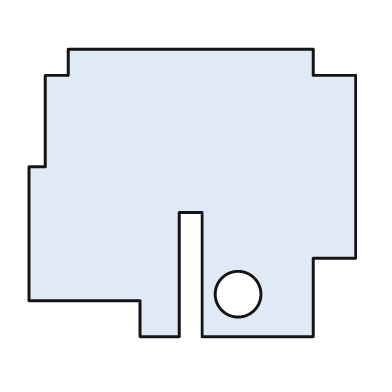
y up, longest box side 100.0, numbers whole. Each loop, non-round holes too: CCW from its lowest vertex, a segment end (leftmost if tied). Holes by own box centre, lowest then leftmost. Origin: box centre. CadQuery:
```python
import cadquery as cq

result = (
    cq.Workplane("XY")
    .moveTo(-16.0, -44.0)
    .lineTo(-4.0, -44.0)
    .lineTo(-4.0, -6.0)
    .lineTo(3.0, -6.0)
    .lineTo(3.0, -44.0)
    .lineTo(37.0, -44.0)
    .lineTo(37.0, -20.0)
    .lineTo(50.0, -20.0)
    .lineTo(50.0, 36.0)
    .lineTo(37.0, 36.0)
    .lineTo(37.0, 44.0)
    .lineTo(-38.0, 44.0)
    .lineTo(-38.0, 36.0)
    .lineTo(-45.0, 36.0)
    .lineTo(-45.0, 8.0)
    .lineTo(-50.0, 8.0)
    .lineTo(-50.0, -33.0)
    .lineTo(-16.0, -33.0)
    .close()
    .moveTo(14.0, -31.0)
    .circle(7.0)
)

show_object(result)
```